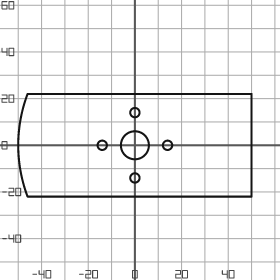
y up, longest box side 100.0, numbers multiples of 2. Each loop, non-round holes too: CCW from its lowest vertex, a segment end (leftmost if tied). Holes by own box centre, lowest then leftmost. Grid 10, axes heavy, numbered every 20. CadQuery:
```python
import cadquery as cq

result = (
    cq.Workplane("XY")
    .moveTo(-46.0, -22.0)
    .lineTo(50.0, -22.0)
    .lineTo(50.0, 22.0)
    .lineTo(-46.0, 22.0)
    .threePointArc((-50.0, 0.0), (-46.0, -22.0))
    .close()
    .moveTo(0.0, -14.0)
    .circle(2.0)
    .moveTo(-14.0, 0.0)
    .circle(2.0)
    .moveTo(0.0, 0.0)
    .circle(6.0)
    .moveTo(14.0, 0.0)
    .circle(2.0)
    .moveTo(0.0, 14.0)
    .circle(2.0)
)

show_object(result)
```